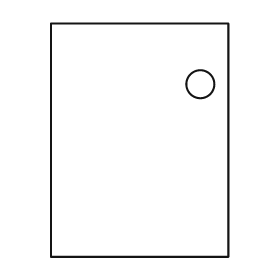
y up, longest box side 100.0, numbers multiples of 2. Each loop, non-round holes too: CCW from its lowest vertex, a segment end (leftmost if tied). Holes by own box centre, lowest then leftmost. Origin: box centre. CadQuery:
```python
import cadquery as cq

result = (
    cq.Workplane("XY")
    .moveTo(-38.0, -50.0)
    .lineTo(38.0, -50.0)
    .lineTo(38.0, 50.0)
    .lineTo(-38.0, 50.0)
    .close()
    .moveTo(26.0, 24.0)
    .circle(6.0)
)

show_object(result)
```